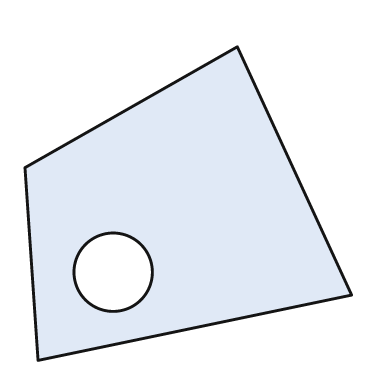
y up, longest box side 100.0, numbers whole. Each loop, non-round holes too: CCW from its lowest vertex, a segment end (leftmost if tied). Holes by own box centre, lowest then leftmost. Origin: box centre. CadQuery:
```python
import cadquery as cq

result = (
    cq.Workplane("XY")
    .moveTo(-46.0, -48.0)
    .lineTo(50.0, -28.0)
    .lineTo(15.0, 48.0)
    .lineTo(-50.0, 11.0)
    .close()
    .moveTo(-23.0, -21.0)
    .circle(12.0)
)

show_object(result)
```